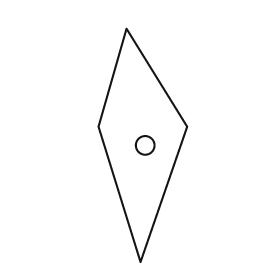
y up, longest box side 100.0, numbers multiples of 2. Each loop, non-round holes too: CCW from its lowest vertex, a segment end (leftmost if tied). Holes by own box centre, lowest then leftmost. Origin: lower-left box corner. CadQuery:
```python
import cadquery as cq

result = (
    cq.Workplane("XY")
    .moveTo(18.0, 0.0)
    .lineTo(38.0, 58.0)
    .lineTo(12.0, 100.0)
    .lineTo(0.0, 58.0)
    .close()
    .moveTo(20.0, 50.0)
    .circle(4.0)
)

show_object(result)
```